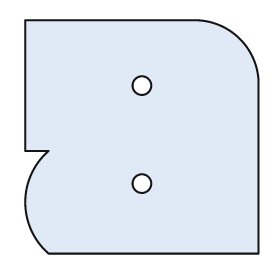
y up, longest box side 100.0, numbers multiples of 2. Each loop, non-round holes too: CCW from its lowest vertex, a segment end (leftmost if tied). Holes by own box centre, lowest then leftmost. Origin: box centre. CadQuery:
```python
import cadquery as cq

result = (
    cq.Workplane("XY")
    .moveTo(-40.0, -50.0)
    .lineTo(50.0, -50.0)
    .lineTo(50.0, 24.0)
    .threePointArc((42.0, 42.0), (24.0, 50.0))
    .lineTo(-50.0, 50.0)
    .lineTo(-50.0, -6.0)
    .lineTo(-40.0, -6.0)
    .threePointArc((-50.0, -28.0), (-40.0, -50.0))
    .close()
    .moveTo(0.0, -20.0)
    .circle(4.0)
    .moveTo(0.0, 22.0)
    .circle(4.0)
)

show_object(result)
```